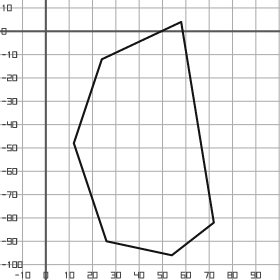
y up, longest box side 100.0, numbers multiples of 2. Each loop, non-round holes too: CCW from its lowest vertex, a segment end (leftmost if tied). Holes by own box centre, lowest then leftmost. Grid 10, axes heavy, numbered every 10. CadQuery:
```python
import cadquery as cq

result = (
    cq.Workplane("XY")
    .moveTo(54.0, -96.0)
    .lineTo(72.0, -82.0)
    .lineTo(58.0, 4.0)
    .lineTo(24.0, -12.0)
    .lineTo(12.0, -48.0)
    .lineTo(26.0, -90.0)
    .close()
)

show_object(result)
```